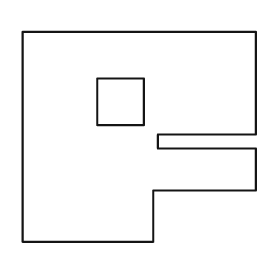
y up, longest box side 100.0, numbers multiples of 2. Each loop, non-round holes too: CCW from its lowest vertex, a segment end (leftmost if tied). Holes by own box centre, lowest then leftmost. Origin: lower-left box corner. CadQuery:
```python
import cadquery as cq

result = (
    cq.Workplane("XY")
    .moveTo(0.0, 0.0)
    .lineTo(56.0, 0.0)
    .lineTo(56.0, 22.0)
    .lineTo(100.0, 22.0)
    .lineTo(100.0, 40.0)
    .lineTo(58.0, 40.0)
    .lineTo(58.0, 46.0)
    .lineTo(100.0, 46.0)
    .lineTo(100.0, 90.0)
    .lineTo(0.0, 90.0)
    .close()
    .moveTo(32.0, 50.0)
    .lineTo(52.0, 50.0)
    .lineTo(52.0, 70.0)
    .lineTo(32.0, 70.0)
    .close()
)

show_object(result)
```